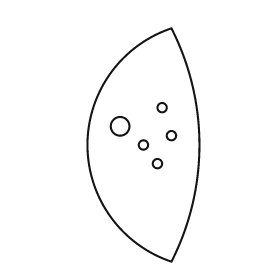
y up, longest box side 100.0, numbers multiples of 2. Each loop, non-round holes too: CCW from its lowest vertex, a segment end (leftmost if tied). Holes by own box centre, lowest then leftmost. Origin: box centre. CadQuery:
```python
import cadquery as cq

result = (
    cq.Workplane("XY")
    .moveTo(12.0, -50.0)
    .threePointArc((24.0, 0.0), (12.0, 50.0))
    .threePointArc((-24.0, 0.0), (12.0, -50.0))
    .close()
    .moveTo(6.0, -8.0)
    .circle(2.0)
    .moveTo(0.0, 0.0)
    .circle(2.0)
    .moveTo(12.0, 4.0)
    .circle(2.0)
    .moveTo(-10.0, 8.0)
    .circle(4.0)
    .moveTo(8.0, 16.0)
    .circle(2.0)
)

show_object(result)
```